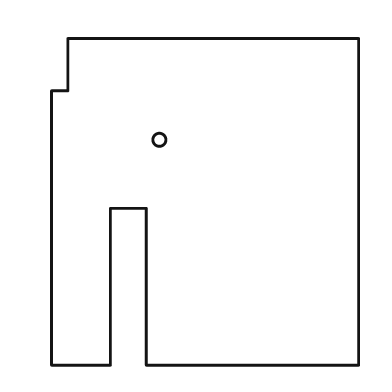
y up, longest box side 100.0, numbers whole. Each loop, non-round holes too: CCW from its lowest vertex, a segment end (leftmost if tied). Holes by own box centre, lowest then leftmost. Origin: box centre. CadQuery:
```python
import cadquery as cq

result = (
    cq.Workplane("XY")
    .moveTo(-47.0, -50.0)
    .lineTo(-29.0, -50.0)
    .lineTo(-29.0, -2.0)
    .lineTo(-18.0, -2.0)
    .lineTo(-18.0, -50.0)
    .lineTo(47.0, -50.0)
    .lineTo(47.0, 50.0)
    .lineTo(-42.0, 50.0)
    .lineTo(-42.0, 34.0)
    .lineTo(-47.0, 34.0)
    .close()
    .moveTo(-14.0, 19.0)
    .circle(2.0)
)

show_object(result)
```